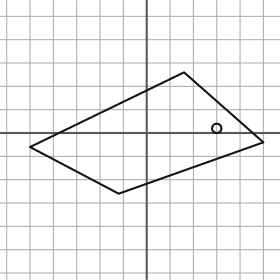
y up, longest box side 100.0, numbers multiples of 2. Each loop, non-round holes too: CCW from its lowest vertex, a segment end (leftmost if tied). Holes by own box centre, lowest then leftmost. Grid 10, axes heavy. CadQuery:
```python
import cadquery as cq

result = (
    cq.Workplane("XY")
    .moveTo(-12.0, -26.0)
    .lineTo(50.0, -4.0)
    .lineTo(16.0, 26.0)
    .lineTo(-50.0, -6.0)
    .close()
    .moveTo(30.0, 2.0)
    .circle(2.0)
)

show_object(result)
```